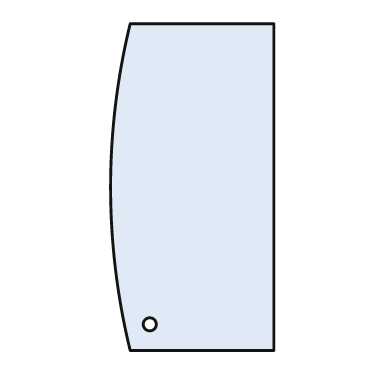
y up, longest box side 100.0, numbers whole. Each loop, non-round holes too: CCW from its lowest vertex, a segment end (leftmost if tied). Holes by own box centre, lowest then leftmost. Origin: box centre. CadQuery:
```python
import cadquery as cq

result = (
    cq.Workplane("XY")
    .moveTo(-19.0, -50.0)
    .lineTo(25.0, -50.0)
    .lineTo(25.0, 50.0)
    .lineTo(-19.0, 50.0)
    .threePointArc((-25.0, 0.0), (-19.0, -50.0))
    .close()
    .moveTo(-13.0, -42.0)
    .circle(2.0)
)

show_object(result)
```